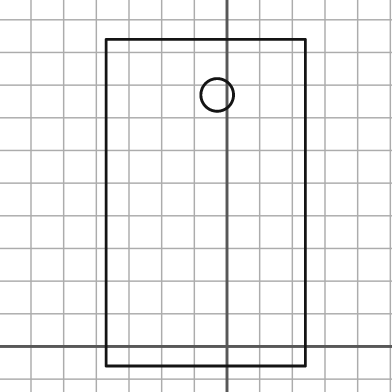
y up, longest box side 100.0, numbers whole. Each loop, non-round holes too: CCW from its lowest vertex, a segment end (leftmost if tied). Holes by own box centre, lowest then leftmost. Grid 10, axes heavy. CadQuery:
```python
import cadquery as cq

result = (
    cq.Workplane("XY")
    .moveTo(-37.0, -6.0)
    .lineTo(24.0, -6.0)
    .lineTo(24.0, 94.0)
    .lineTo(-37.0, 94.0)
    .close()
    .moveTo(-3.0, 77.0)
    .circle(5.0)
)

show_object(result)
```